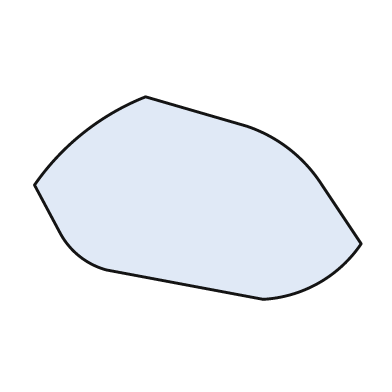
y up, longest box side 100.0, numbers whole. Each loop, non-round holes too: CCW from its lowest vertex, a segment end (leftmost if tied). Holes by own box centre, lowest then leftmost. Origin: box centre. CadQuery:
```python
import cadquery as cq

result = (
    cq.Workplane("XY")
    .moveTo(20.0, -31.0)
    .threePointArc((37.0, -26.0), (50.0, -14.0))
    .lineTo(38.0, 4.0)
    .threePointArc((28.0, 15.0), (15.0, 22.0))
    .lineTo(-16.0, 31.0)
    .threePointArc((-35.0, 20.0), (-50.0, 4.0))
    .lineTo(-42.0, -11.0)
    .threePointArc((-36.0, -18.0), (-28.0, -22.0))
    .close()
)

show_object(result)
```